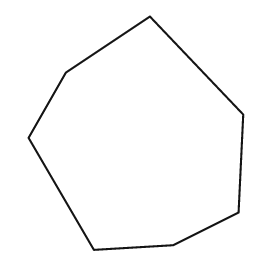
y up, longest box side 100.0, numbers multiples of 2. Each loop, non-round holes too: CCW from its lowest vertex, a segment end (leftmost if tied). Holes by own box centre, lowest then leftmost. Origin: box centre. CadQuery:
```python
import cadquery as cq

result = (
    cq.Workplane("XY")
    .moveTo(-18.0, -50.0)
    .lineTo(16.0, -48.0)
    .lineTo(44.0, -34.0)
    .lineTo(46.0, 8.0)
    .lineTo(6.0, 50.0)
    .lineTo(-30.0, 26.0)
    .lineTo(-46.0, -2.0)
    .close()
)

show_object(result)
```